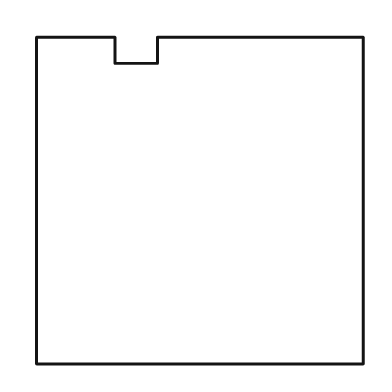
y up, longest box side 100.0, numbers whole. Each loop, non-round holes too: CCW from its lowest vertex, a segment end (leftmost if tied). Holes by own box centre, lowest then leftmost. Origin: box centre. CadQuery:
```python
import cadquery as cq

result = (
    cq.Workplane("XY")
    .moveTo(-50.0, -50.0)
    .lineTo(50.0, -50.0)
    .lineTo(50.0, 50.0)
    .lineTo(-13.0, 50.0)
    .lineTo(-13.0, 42.0)
    .lineTo(-26.0, 42.0)
    .lineTo(-26.0, 50.0)
    .lineTo(-50.0, 50.0)
    .close()
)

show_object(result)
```